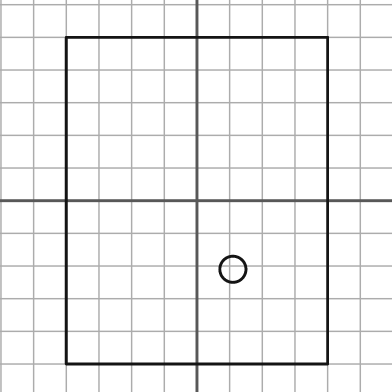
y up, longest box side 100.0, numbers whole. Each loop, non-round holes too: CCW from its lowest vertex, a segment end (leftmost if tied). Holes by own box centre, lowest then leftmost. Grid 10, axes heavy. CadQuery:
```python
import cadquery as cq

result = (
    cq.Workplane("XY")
    .moveTo(-40.0, -50.0)
    .lineTo(40.0, -50.0)
    .lineTo(40.0, 50.0)
    .lineTo(-40.0, 50.0)
    .close()
    .moveTo(11.0, -21.0)
    .circle(4.0)
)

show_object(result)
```